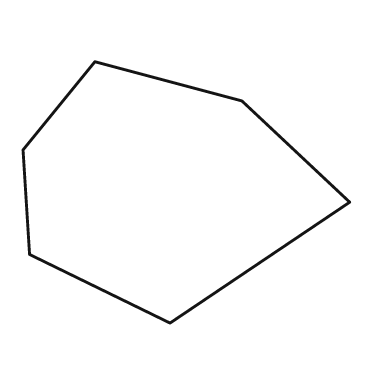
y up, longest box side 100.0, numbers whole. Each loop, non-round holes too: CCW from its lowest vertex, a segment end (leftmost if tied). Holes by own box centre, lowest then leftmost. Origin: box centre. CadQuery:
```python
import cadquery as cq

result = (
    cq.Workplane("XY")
    .moveTo(-5.0, -40.0)
    .lineTo(50.0, -3.0)
    .lineTo(17.0, 28.0)
    .lineTo(-28.0, 40.0)
    .lineTo(-50.0, 13.0)
    .lineTo(-48.0, -19.0)
    .close()
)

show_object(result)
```